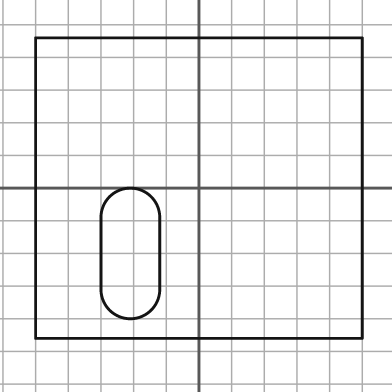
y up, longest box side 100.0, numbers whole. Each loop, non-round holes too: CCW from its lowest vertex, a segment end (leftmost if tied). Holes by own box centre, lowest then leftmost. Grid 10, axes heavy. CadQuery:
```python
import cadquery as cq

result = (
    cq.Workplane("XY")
    .moveTo(-50.0, -46.0)
    .lineTo(50.0, -46.0)
    .lineTo(50.0, 46.0)
    .lineTo(-50.0, 46.0)
    .close()
    .moveTo(-30.0, -31.0)
    .threePointArc((-21.0, -40.0), (-12.0, -31.0))
    .lineTo(-12.0, -9.0)
    .threePointArc((-21.0, 0.0), (-30.0, -9.0))
    .close()
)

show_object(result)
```